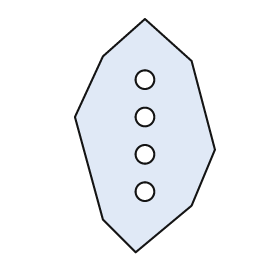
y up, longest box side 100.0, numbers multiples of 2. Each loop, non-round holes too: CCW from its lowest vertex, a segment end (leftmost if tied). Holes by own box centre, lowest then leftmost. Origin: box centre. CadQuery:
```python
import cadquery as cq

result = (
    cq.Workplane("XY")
    .moveTo(-4.0, -50.0)
    .lineTo(20.0, -30.0)
    .lineTo(30.0, -6.0)
    .lineTo(20.0, 32.0)
    .lineTo(0.0, 50.0)
    .lineTo(-18.0, 34.0)
    .lineTo(-30.0, 8.0)
    .lineTo(-18.0, -36.0)
    .close()
    .moveTo(0.0, -24.0)
    .circle(4.0)
    .moveTo(0.0, -8.0)
    .circle(4.0)
    .moveTo(0.0, 8.0)
    .circle(4.0)
    .moveTo(0.0, 24.0)
    .circle(4.0)
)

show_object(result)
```